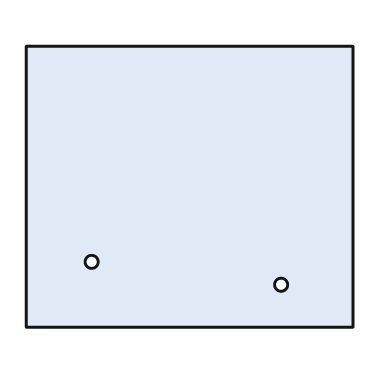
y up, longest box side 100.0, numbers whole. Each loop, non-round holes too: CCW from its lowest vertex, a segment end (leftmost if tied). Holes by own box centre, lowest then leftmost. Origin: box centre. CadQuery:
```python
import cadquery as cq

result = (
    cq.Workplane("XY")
    .moveTo(-50.0, -43.0)
    .lineTo(50.0, -43.0)
    .lineTo(50.0, 43.0)
    .lineTo(-50.0, 43.0)
    .close()
    .moveTo(28.0, -30.0)
    .circle(2.0)
    .moveTo(-30.0, -23.0)
    .circle(2.0)
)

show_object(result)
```